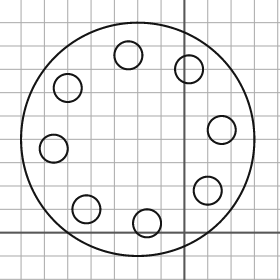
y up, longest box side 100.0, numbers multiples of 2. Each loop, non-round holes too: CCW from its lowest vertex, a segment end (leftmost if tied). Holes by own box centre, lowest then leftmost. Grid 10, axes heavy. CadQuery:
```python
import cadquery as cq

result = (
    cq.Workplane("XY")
    .moveTo(-20.0, 40.0)
    .circle(50.0)
    .moveTo(-16.0, 4.0)
    .circle(6.0)
    .moveTo(-42.0, 10.0)
    .circle(6.0)
    .moveTo(10.0, 18.0)
    .circle(6.0)
    .moveTo(-56.0, 36.0)
    .circle(6.0)
    .moveTo(16.0, 44.0)
    .circle(6.0)
    .moveTo(-50.0, 62.0)
    .circle(6.0)
    .moveTo(2.0, 70.0)
    .circle(6.0)
    .moveTo(-24.0, 76.0)
    .circle(6.0)
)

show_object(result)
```